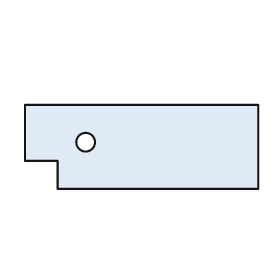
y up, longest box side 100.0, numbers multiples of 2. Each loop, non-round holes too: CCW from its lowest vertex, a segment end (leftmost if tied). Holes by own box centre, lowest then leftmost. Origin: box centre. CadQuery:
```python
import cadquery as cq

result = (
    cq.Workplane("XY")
    .moveTo(-36.0, -18.0)
    .lineTo(50.0, -18.0)
    .lineTo(50.0, 18.0)
    .lineTo(-50.0, 18.0)
    .lineTo(-50.0, -6.0)
    .lineTo(-36.0, -6.0)
    .close()
    .moveTo(-24.0, 2.0)
    .circle(4.0)
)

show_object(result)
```